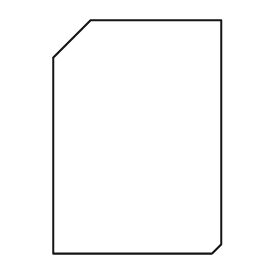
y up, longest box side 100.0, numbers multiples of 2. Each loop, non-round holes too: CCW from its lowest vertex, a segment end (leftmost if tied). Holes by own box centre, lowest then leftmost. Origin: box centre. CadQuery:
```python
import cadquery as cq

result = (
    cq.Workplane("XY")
    .moveTo(-36.0, -50.0)
    .lineTo(32.0, -50.0)
    .lineTo(36.0, -46.0)
    .lineTo(36.0, 50.0)
    .lineTo(-20.0, 50.0)
    .lineTo(-36.0, 34.0)
    .close()
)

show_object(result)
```